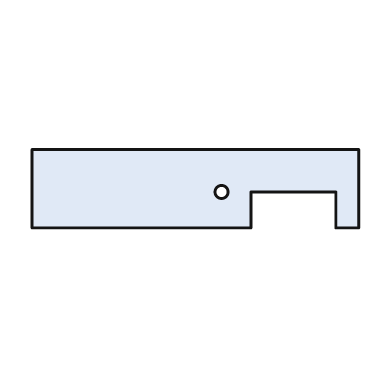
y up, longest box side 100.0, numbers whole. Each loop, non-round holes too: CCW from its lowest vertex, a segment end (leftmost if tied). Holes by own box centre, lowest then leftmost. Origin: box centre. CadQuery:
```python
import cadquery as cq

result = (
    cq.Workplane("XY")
    .moveTo(-50.0, -12.0)
    .lineTo(17.0, -12.0)
    .lineTo(17.0, -1.0)
    .lineTo(43.0, -1.0)
    .lineTo(43.0, -12.0)
    .lineTo(50.0, -12.0)
    .lineTo(50.0, 12.0)
    .lineTo(-50.0, 12.0)
    .close()
    .moveTo(8.0, -1.0)
    .circle(2.0)
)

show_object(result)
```